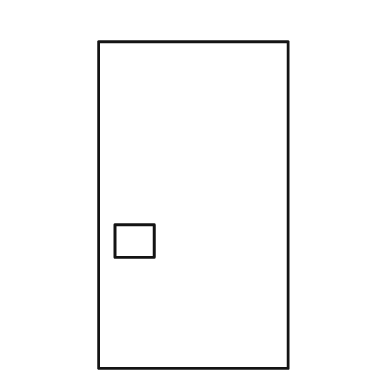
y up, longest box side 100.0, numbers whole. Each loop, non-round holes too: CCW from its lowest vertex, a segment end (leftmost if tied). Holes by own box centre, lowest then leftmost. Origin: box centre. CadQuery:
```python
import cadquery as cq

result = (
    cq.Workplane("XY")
    .moveTo(-29.0, -50.0)
    .lineTo(29.0, -50.0)
    .lineTo(29.0, 50.0)
    .lineTo(-29.0, 50.0)
    .close()
    .moveTo(-24.0, -16.0)
    .lineTo(-12.0, -16.0)
    .lineTo(-12.0, -6.0)
    .lineTo(-24.0, -6.0)
    .close()
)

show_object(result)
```